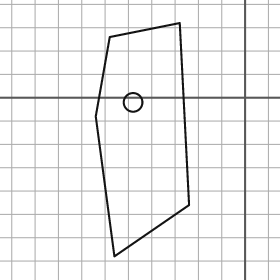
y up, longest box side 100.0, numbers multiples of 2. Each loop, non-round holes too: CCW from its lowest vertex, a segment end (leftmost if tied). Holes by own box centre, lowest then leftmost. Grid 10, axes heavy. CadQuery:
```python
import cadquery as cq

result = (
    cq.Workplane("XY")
    .moveTo(-56.0, -68.0)
    .lineTo(-24.0, -46.0)
    .lineTo(-28.0, 32.0)
    .lineTo(-58.0, 26.0)
    .lineTo(-64.0, -8.0)
    .close()
    .moveTo(-48.0, -2.0)
    .circle(4.0)
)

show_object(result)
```